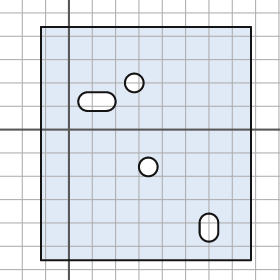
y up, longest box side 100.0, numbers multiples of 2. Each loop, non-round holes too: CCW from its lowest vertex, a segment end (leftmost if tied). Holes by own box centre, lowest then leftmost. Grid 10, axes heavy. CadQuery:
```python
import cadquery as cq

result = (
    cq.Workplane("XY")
    .moveTo(-12.0, -56.0)
    .lineTo(78.0, -56.0)
    .lineTo(78.0, 44.0)
    .lineTo(-12.0, 44.0)
    .close()
    .moveTo(56.0, -44.0)
    .threePointArc((60.0, -48.0), (64.0, -44.0))
    .lineTo(64.0, -40.0)
    .threePointArc((60.0, -36.0), (56.0, -40.0))
    .close()
    .moveTo(34.0, -16.0)
    .circle(4.0)
    .moveTo(8.0, 8.0)
    .lineTo(16.0, 8.0)
    .threePointArc((20.0, 12.0), (16.0, 16.0))
    .lineTo(8.0, 16.0)
    .threePointArc((4.0, 12.0), (8.0, 8.0))
    .close()
    .moveTo(28.0, 20.0)
    .circle(4.0)
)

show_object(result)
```